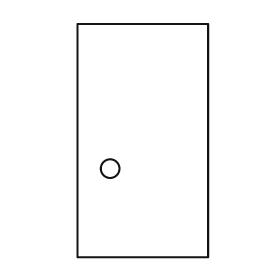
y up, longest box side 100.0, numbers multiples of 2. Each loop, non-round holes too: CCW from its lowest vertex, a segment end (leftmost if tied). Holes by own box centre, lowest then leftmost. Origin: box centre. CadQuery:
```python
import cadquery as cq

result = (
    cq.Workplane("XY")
    .moveTo(-28.0, -50.0)
    .lineTo(28.0, -50.0)
    .lineTo(28.0, 50.0)
    .lineTo(-28.0, 50.0)
    .close()
    .moveTo(-14.0, -12.0)
    .circle(4.0)
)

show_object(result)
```